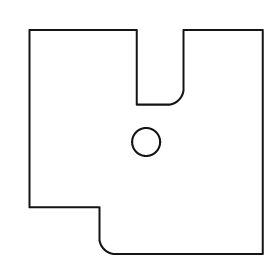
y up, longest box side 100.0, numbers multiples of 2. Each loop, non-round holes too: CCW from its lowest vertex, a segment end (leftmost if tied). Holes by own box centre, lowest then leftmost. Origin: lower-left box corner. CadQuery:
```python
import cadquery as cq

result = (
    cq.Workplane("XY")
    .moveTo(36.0, 0.0)
    .lineTo(100.0, 0.0)
    .lineTo(100.0, 96.0)
    .lineTo(66.0, 96.0)
    .lineTo(66.0, 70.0)
    .threePointArc((64.0, 66.0), (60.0, 64.0))
    .lineTo(46.0, 64.0)
    .lineTo(46.0, 96.0)
    .lineTo(0.0, 96.0)
    .lineTo(0.0, 20.0)
    .lineTo(30.0, 20.0)
    .lineTo(30.0, 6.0)
    .threePointArc((32.0, 2.0), (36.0, 0.0))
    .close()
    .moveTo(50.0, 48.0)
    .circle(6.0)
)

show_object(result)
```